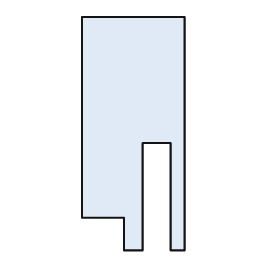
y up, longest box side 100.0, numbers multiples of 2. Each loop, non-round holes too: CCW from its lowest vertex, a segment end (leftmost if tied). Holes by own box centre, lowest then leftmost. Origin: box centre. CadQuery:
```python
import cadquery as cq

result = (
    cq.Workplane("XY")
    .moveTo(-4.0, -50.0)
    .lineTo(4.0, -50.0)
    .lineTo(4.0, -4.0)
    .lineTo(16.0, -4.0)
    .lineTo(16.0, -50.0)
    .lineTo(22.0, -50.0)
    .lineTo(22.0, 50.0)
    .lineTo(-22.0, 50.0)
    .lineTo(-22.0, -36.0)
    .lineTo(-4.0, -36.0)
    .close()
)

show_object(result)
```